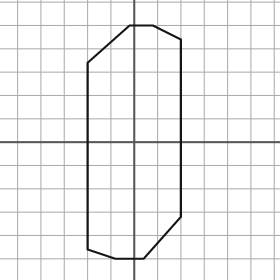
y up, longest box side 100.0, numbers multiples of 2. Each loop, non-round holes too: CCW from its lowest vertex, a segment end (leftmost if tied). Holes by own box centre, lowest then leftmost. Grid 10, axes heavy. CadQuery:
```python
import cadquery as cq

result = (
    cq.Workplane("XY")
    .moveTo(-8.0, -50.0)
    .lineTo(4.0, -50.0)
    .lineTo(20.0, -32.0)
    .lineTo(20.0, 44.0)
    .lineTo(8.0, 50.0)
    .lineTo(-2.0, 50.0)
    .lineTo(-20.0, 34.0)
    .lineTo(-20.0, -46.0)
    .close()
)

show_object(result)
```